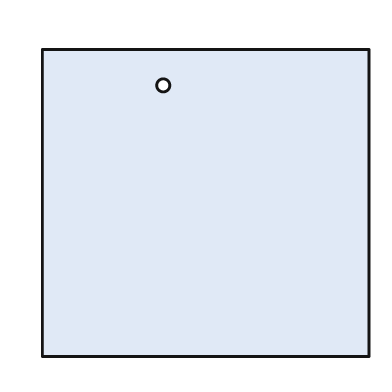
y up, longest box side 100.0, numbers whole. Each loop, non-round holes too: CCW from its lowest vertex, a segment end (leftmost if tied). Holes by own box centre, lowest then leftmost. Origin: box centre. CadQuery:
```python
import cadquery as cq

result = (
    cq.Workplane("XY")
    .moveTo(-50.0, -47.0)
    .lineTo(50.0, -47.0)
    .lineTo(50.0, 47.0)
    .lineTo(-50.0, 47.0)
    .close()
    .moveTo(-13.0, 36.0)
    .circle(2.0)
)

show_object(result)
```